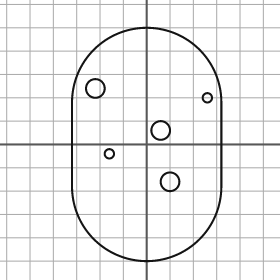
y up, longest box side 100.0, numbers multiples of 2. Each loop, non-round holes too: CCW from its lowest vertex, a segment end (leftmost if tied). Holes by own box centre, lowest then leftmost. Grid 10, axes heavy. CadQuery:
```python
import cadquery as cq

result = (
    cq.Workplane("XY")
    .moveTo(-32.0, -18.0)
    .threePointArc((0.0, -50.0), (32.0, -18.0))
    .lineTo(32.0, 18.0)
    .threePointArc((0.0, 50.0), (-32.0, 18.0))
    .close()
    .moveTo(10.0, -16.0)
    .circle(4.0)
    .moveTo(-16.0, -4.0)
    .circle(2.0)
    .moveTo(6.0, 6.0)
    .circle(4.0)
    .moveTo(26.0, 20.0)
    .circle(2.0)
    .moveTo(-22.0, 24.0)
    .circle(4.0)
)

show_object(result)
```